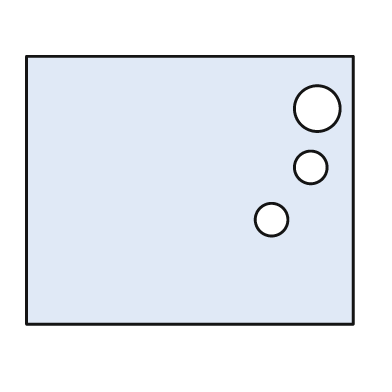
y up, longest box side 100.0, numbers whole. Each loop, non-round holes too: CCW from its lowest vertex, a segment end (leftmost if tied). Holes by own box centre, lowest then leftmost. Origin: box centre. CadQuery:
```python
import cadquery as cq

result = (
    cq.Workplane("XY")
    .moveTo(-50.0, -41.0)
    .lineTo(50.0, -41.0)
    .lineTo(50.0, 41.0)
    .lineTo(-50.0, 41.0)
    .close()
    .moveTo(25.0, -9.0)
    .circle(5.0)
    .moveTo(37.0, 7.0)
    .circle(5.0)
    .moveTo(39.0, 25.0)
    .circle(7.0)
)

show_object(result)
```